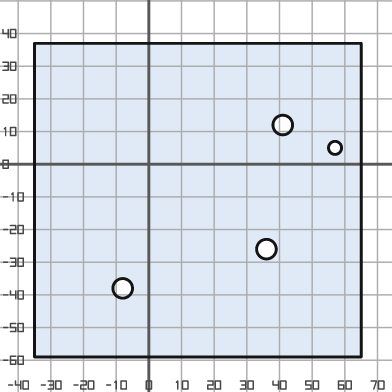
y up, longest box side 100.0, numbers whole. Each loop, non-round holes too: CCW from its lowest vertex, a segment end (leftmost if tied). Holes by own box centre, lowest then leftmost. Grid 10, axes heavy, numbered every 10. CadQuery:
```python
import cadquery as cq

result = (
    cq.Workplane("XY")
    .moveTo(-35.0, -59.0)
    .lineTo(65.0, -59.0)
    .lineTo(65.0, 37.0)
    .lineTo(-35.0, 37.0)
    .close()
    .moveTo(-8.0, -38.0)
    .circle(3.0)
    .moveTo(36.0, -26.0)
    .circle(3.0)
    .moveTo(57.0, 5.0)
    .circle(2.0)
    .moveTo(41.0, 12.0)
    .circle(3.0)
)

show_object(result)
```